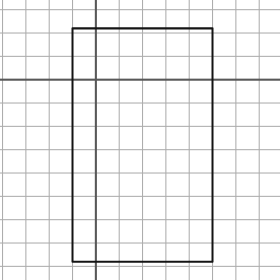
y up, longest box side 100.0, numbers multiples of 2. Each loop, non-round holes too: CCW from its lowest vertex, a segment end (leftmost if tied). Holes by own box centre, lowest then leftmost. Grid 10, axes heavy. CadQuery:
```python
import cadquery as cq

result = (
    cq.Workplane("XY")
    .moveTo(-10.0, -78.0)
    .lineTo(50.0, -78.0)
    .lineTo(50.0, 22.0)
    .lineTo(-10.0, 22.0)
    .close()
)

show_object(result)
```